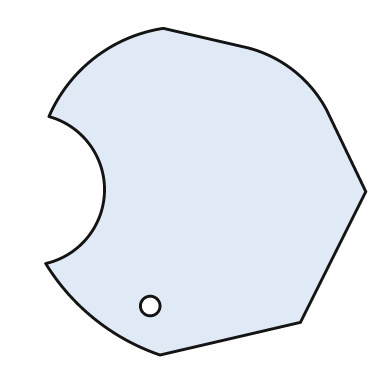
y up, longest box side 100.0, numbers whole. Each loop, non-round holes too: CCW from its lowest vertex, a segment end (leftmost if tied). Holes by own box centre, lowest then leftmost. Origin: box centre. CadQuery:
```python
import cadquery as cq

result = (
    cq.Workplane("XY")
    .moveTo(-14.0, -50.0)
    .lineTo(29.0, -40.0)
    .lineTo(49.0, 0.0)
    .lineTo(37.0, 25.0)
    .threePointArc((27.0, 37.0), (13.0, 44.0))
    .lineTo(-13.0, 50.0)
    .threePointArc((-34.0, 41.0), (-48.0, 23.0))
    .threePointArc((-31.0, 0.0), (-49.0, -22.0))
    .threePointArc((-34.0, -39.0), (-14.0, -50.0))
    .close()
    .moveTo(-17.0, -35.0)
    .circle(3.0)
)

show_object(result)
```